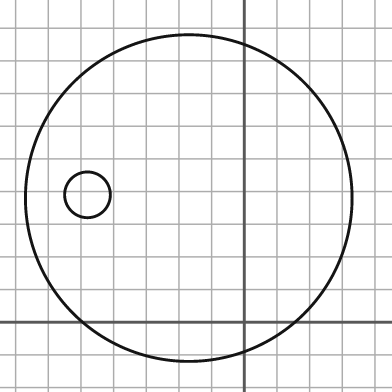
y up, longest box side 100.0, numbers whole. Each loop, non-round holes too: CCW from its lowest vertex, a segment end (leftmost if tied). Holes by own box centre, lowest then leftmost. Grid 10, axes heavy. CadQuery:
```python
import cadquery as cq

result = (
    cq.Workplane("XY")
    .moveTo(-17.0, 38.0)
    .circle(50.0)
    .moveTo(-48.0, 39.0)
    .circle(7.0)
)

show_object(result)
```